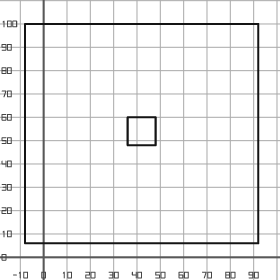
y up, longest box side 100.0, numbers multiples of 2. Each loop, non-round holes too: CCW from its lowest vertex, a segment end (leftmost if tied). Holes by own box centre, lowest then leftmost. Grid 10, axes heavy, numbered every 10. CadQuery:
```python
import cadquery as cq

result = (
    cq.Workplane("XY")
    .moveTo(-8.0, 6.0)
    .lineTo(92.0, 6.0)
    .lineTo(92.0, 100.0)
    .lineTo(-8.0, 100.0)
    .close()
    .moveTo(36.0, 48.0)
    .lineTo(48.0, 48.0)
    .lineTo(48.0, 60.0)
    .lineTo(36.0, 60.0)
    .close()
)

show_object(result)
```